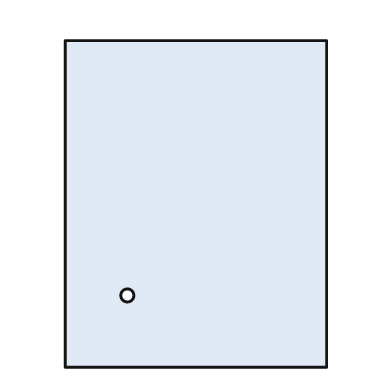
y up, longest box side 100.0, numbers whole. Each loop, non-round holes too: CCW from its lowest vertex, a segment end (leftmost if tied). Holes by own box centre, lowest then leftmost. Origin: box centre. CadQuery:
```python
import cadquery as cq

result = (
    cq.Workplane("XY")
    .moveTo(-40.0, -50.0)
    .lineTo(40.0, -50.0)
    .lineTo(40.0, 50.0)
    .lineTo(-40.0, 50.0)
    .close()
    .moveTo(-21.0, -28.0)
    .circle(2.0)
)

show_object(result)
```